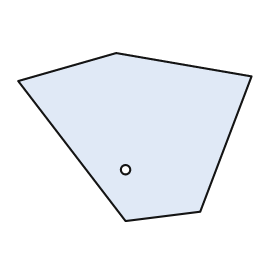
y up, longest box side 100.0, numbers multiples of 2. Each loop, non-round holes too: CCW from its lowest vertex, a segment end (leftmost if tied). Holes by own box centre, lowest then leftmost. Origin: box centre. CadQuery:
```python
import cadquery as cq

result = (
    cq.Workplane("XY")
    .moveTo(-4.0, -36.0)
    .lineTo(28.0, -32.0)
    .lineTo(50.0, 26.0)
    .lineTo(-8.0, 36.0)
    .lineTo(-50.0, 24.0)
    .close()
    .moveTo(-4.0, -14.0)
    .circle(2.0)
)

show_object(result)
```